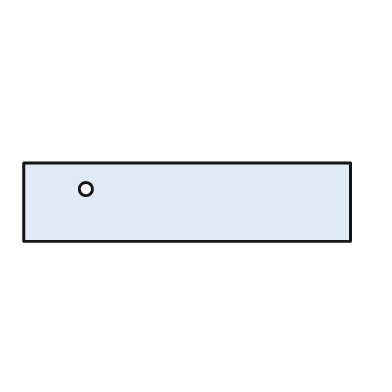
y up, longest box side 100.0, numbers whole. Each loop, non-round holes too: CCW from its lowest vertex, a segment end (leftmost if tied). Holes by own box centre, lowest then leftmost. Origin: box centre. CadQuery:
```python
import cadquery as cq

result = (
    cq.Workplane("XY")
    .moveTo(-50.0, -12.0)
    .lineTo(50.0, -12.0)
    .lineTo(50.0, 12.0)
    .lineTo(-50.0, 12.0)
    .close()
    .moveTo(-31.0, 4.0)
    .circle(2.0)
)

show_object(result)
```